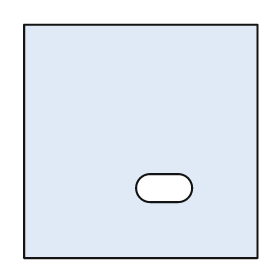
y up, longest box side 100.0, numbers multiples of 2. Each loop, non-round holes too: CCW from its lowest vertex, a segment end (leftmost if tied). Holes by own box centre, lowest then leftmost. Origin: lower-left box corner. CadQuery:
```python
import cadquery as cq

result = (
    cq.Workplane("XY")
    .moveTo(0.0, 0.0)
    .lineTo(100.0, 0.0)
    .lineTo(100.0, 100.0)
    .lineTo(0.0, 100.0)
    .close()
    .moveTo(54.0, 24.0)
    .lineTo(66.0, 24.0)
    .threePointArc((72.0, 30.0), (66.0, 36.0))
    .lineTo(54.0, 36.0)
    .threePointArc((48.0, 30.0), (54.0, 24.0))
    .close()
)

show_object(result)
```